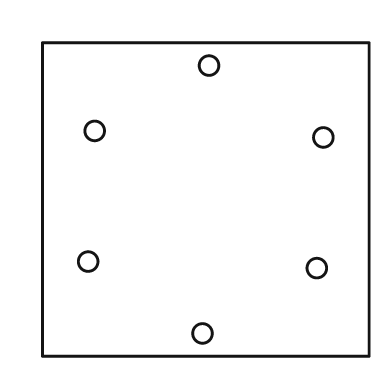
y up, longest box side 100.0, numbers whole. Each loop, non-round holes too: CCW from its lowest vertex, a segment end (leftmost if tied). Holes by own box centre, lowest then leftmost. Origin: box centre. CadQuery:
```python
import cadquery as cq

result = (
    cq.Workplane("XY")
    .moveTo(-50.0, -48.0)
    .lineTo(50.0, -48.0)
    .lineTo(50.0, 48.0)
    .lineTo(-50.0, 48.0)
    .close()
    .moveTo(-1.0, -41.0)
    .circle(3.0)
    .moveTo(34.0, -21.0)
    .circle(3.0)
    .moveTo(-36.0, -19.0)
    .circle(3.0)
    .moveTo(36.0, 19.0)
    .circle(3.0)
    .moveTo(-34.0, 21.0)
    .circle(3.0)
    .moveTo(1.0, 41.0)
    .circle(3.0)
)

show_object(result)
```